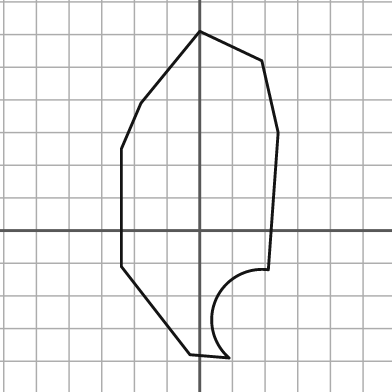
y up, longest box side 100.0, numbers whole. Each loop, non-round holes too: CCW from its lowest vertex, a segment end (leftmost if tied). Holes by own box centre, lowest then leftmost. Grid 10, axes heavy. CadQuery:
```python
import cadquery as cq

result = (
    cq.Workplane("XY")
    .moveTo(9.0, -39.0)
    .threePointArc((5.0, -21.0), (21.0, -12.0))
    .lineTo(24.0, 30.0)
    .lineTo(19.0, 52.0)
    .lineTo(0.0, 61.0)
    .lineTo(-18.0, 39.0)
    .lineTo(-24.0, 25.0)
    .lineTo(-24.0, -11.0)
    .lineTo(-3.0, -38.0)
    .close()
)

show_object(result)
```